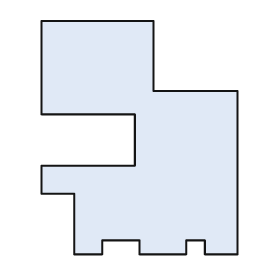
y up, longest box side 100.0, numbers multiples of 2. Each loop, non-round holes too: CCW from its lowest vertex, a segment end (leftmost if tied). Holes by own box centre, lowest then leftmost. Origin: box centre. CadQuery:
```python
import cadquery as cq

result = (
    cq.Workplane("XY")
    .moveTo(-28.0, -50.0)
    .lineTo(-16.0, -50.0)
    .lineTo(-16.0, -44.0)
    .lineTo(0.0, -44.0)
    .lineTo(0.0, -50.0)
    .lineTo(20.0, -50.0)
    .lineTo(20.0, -44.0)
    .lineTo(28.0, -44.0)
    .lineTo(28.0, -50.0)
    .lineTo(42.0, -50.0)
    .lineTo(42.0, 20.0)
    .lineTo(6.0, 20.0)
    .lineTo(6.0, 50.0)
    .lineTo(-42.0, 50.0)
    .lineTo(-42.0, 10.0)
    .lineTo(-2.0, 10.0)
    .lineTo(-2.0, -12.0)
    .lineTo(-42.0, -12.0)
    .lineTo(-42.0, -24.0)
    .lineTo(-28.0, -24.0)
    .close()
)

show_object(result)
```